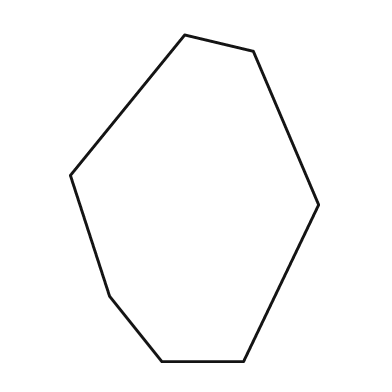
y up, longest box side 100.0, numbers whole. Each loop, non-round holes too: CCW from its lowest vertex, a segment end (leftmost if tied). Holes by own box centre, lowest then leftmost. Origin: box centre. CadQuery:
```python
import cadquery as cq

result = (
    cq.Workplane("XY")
    .moveTo(-10.0, -50.0)
    .lineTo(15.0, -50.0)
    .lineTo(38.0, -2.0)
    .lineTo(18.0, 45.0)
    .lineTo(-3.0, 50.0)
    .lineTo(-38.0, 7.0)
    .lineTo(-26.0, -30.0)
    .close()
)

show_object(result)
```